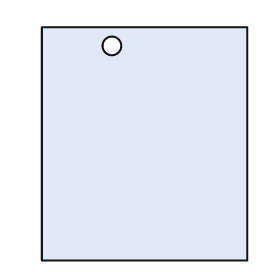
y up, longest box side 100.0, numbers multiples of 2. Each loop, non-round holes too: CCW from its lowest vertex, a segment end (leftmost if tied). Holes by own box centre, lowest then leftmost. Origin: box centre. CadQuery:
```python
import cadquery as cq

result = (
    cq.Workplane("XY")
    .moveTo(-44.0, -50.0)
    .lineTo(44.0, -50.0)
    .lineTo(44.0, 50.0)
    .lineTo(-44.0, 50.0)
    .close()
    .moveTo(-14.0, 42.0)
    .circle(4.0)
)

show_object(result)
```